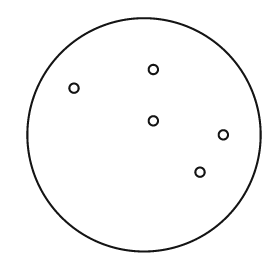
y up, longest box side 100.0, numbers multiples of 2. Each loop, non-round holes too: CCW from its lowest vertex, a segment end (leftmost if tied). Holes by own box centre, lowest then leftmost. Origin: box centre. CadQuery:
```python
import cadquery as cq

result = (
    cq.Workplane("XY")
    .moveTo(0.0, 0.0)
    .circle(50.0)
    .moveTo(24.0, -16.0)
    .circle(2.0)
    .moveTo(34.0, 0.0)
    .circle(2.0)
    .moveTo(4.0, 6.0)
    .circle(2.0)
    .moveTo(-30.0, 20.0)
    .circle(2.0)
    .moveTo(4.0, 28.0)
    .circle(2.0)
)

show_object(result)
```